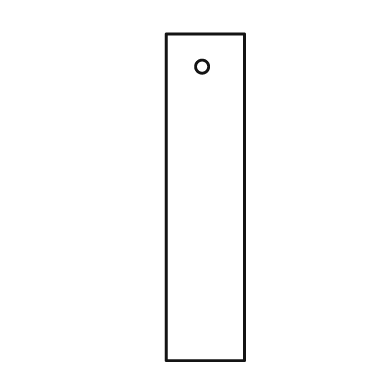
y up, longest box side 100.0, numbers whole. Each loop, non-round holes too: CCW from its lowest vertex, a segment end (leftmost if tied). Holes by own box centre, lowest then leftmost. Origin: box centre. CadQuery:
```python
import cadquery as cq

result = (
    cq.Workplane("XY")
    .moveTo(-12.0, -50.0)
    .lineTo(12.0, -50.0)
    .lineTo(12.0, 50.0)
    .lineTo(-12.0, 50.0)
    .close()
    .moveTo(-1.0, 40.0)
    .circle(2.0)
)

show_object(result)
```